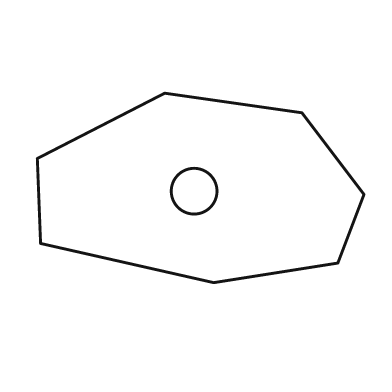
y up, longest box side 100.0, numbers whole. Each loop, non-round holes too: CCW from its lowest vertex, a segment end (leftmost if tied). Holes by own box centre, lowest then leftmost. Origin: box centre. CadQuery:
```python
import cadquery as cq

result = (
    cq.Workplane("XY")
    .moveTo(4.0, -29.0)
    .lineTo(42.0, -23.0)
    .lineTo(50.0, -2.0)
    .lineTo(31.0, 23.0)
    .lineTo(-11.0, 29.0)
    .lineTo(-50.0, 9.0)
    .lineTo(-49.0, -17.0)
    .close()
    .moveTo(-2.0, -1.0)
    .circle(7.0)
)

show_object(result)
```